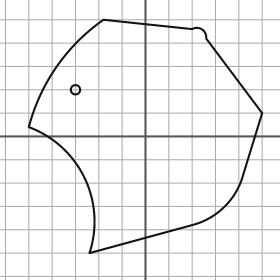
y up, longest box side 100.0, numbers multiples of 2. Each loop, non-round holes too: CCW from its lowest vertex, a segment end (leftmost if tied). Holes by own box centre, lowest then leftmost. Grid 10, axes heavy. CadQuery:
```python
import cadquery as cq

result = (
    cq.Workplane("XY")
    .moveTo(-24.0, -50.0)
    .lineTo(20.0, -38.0)
    .threePointArc((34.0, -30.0), (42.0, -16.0))
    .lineTo(50.0, 10.0)
    .lineTo(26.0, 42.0)
    .threePointArc((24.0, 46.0), (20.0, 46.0))
    .lineTo(-18.0, 50.0)
    .threePointArc((-38.0, 30.0), (-50.0, 4.0))
    .threePointArc((-26.0, -18.0), (-24.0, -50.0))
    .close()
    .moveTo(-30.0, 20.0)
    .circle(2.0)
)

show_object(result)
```